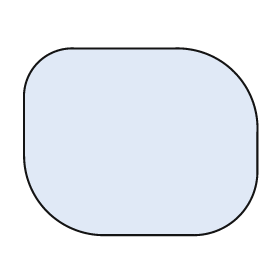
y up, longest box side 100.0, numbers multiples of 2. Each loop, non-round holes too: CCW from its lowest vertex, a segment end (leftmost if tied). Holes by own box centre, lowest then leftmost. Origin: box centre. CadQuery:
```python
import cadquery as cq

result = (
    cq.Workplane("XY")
    .moveTo(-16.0, -40.0)
    .lineTo(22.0, -40.0)
    .threePointArc((42.0, -32.0), (50.0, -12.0))
    .lineTo(50.0, 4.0)
    .threePointArc((40.0, 30.0), (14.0, 40.0))
    .lineTo(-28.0, 40.0)
    .threePointArc((-44.0, 34.0), (-50.0, 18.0))
    .lineTo(-50.0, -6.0)
    .threePointArc((-40.0, -30.0), (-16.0, -40.0))
    .close()
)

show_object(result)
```